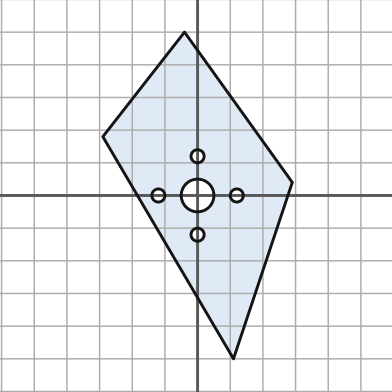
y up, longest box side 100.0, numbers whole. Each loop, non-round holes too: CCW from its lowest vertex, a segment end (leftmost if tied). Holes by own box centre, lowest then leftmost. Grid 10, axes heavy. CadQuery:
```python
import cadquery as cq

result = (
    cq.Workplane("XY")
    .moveTo(11.0, -50.0)
    .lineTo(29.0, 4.0)
    .lineTo(-4.0, 50.0)
    .lineTo(-29.0, 18.0)
    .close()
    .moveTo(0.0, -12.0)
    .circle(2.0)
    .moveTo(-12.0, 0.0)
    .circle(2.0)
    .moveTo(0.0, 0.0)
    .circle(5.0)
    .moveTo(12.0, 0.0)
    .circle(2.0)
    .moveTo(0.0, 12.0)
    .circle(2.0)
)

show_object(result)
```